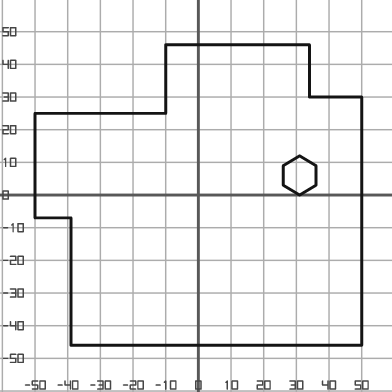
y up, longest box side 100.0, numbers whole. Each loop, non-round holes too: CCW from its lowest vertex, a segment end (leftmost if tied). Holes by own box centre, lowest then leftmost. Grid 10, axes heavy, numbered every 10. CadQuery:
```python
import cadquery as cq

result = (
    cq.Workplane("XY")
    .moveTo(-39.0, -46.0)
    .lineTo(50.0, -46.0)
    .lineTo(50.0, 30.0)
    .lineTo(34.0, 30.0)
    .lineTo(34.0, 46.0)
    .lineTo(-10.0, 46.0)
    .lineTo(-10.0, 25.0)
    .lineTo(-50.0, 25.0)
    .lineTo(-50.0, -7.0)
    .lineTo(-39.0, -7.0)
    .close()
    .moveTo(31.0, 0.0)
    .lineTo(36.0, 3.0)
    .lineTo(36.0, 9.0)
    .lineTo(31.0, 12.0)
    .lineTo(26.0, 9.0)
    .lineTo(26.0, 3.0)
    .close()
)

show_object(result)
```